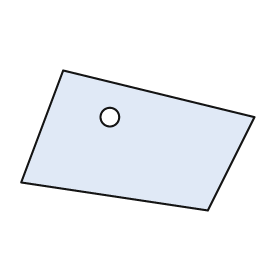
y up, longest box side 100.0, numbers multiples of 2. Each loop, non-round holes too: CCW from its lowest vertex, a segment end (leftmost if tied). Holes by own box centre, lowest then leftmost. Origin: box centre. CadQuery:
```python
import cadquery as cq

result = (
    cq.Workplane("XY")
    .moveTo(30.0, -30.0)
    .lineTo(50.0, 10.0)
    .lineTo(-32.0, 30.0)
    .lineTo(-50.0, -18.0)
    .close()
    .moveTo(-12.0, 10.0)
    .circle(4.0)
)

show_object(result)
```